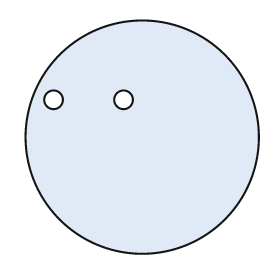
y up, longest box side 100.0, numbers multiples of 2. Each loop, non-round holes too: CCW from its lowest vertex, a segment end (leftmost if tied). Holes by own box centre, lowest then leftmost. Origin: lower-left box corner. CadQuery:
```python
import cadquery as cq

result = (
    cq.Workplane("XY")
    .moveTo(50.0, 50.0)
    .circle(50.0)
    .moveTo(12.0, 66.0)
    .circle(4.0)
    .moveTo(42.0, 66.0)
    .circle(4.0)
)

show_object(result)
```